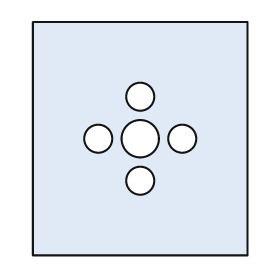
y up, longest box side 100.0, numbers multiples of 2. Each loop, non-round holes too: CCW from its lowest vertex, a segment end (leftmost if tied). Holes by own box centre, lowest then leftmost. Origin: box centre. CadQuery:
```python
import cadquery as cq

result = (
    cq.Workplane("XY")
    .moveTo(-46.0, -50.0)
    .lineTo(46.0, -50.0)
    .lineTo(46.0, 50.0)
    .lineTo(-46.0, 50.0)
    .close()
    .moveTo(0.0, -18.0)
    .circle(6.0)
    .moveTo(-18.0, 0.0)
    .circle(6.0)
    .moveTo(0.0, 0.0)
    .circle(8.0)
    .moveTo(18.0, 0.0)
    .circle(6.0)
    .moveTo(0.0, 18.0)
    .circle(6.0)
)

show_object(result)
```